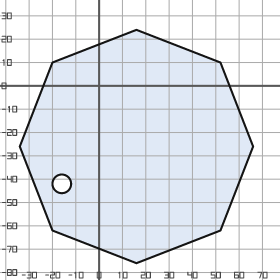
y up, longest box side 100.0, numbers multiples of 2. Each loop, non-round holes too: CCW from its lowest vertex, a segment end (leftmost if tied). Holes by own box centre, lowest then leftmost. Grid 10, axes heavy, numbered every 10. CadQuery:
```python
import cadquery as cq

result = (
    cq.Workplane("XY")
    .moveTo(16.0, -76.0)
    .lineTo(52.0, -62.0)
    .lineTo(66.0, -26.0)
    .lineTo(52.0, 10.0)
    .lineTo(16.0, 24.0)
    .lineTo(-20.0, 10.0)
    .lineTo(-34.0, -26.0)
    .lineTo(-20.0, -62.0)
    .close()
    .moveTo(-16.0, -42.0)
    .circle(4.0)
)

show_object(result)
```